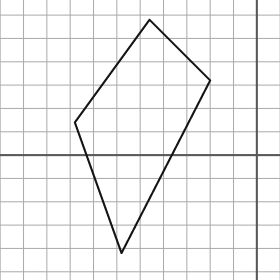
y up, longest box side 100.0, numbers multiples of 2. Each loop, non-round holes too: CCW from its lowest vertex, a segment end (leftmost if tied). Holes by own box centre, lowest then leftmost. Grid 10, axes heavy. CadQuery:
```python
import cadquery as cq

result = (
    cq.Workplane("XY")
    .moveTo(-58.0, -42.0)
    .lineTo(-20.0, 32.0)
    .lineTo(-46.0, 58.0)
    .lineTo(-78.0, 14.0)
    .close()
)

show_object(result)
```